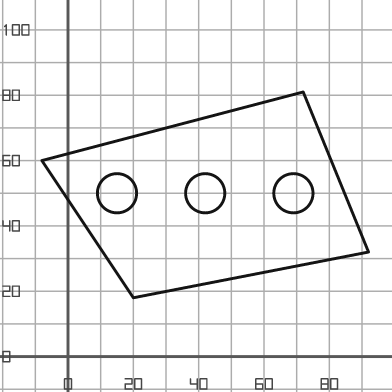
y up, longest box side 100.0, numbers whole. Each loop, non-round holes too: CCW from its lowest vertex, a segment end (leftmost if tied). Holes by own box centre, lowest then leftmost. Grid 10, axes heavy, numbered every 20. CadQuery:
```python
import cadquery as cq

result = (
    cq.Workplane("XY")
    .moveTo(20.0, 18.0)
    .lineTo(92.0, 32.0)
    .lineTo(72.0, 81.0)
    .lineTo(-8.0, 60.0)
    .close()
    .moveTo(15.0, 50.0)
    .circle(6.0)
    .moveTo(42.0, 50.0)
    .circle(6.0)
    .moveTo(69.0, 50.0)
    .circle(6.0)
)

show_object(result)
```